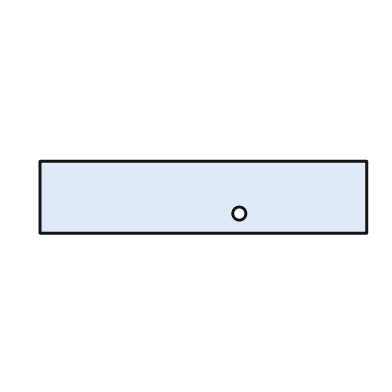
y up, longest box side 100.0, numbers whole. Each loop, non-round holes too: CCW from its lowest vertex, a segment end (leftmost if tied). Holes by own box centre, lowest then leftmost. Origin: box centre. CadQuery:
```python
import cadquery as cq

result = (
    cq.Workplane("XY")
    .moveTo(-50.0, -11.0)
    .lineTo(50.0, -11.0)
    .lineTo(50.0, 11.0)
    .lineTo(-50.0, 11.0)
    .close()
    .moveTo(11.0, -5.0)
    .circle(2.0)
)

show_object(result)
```